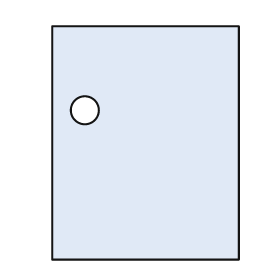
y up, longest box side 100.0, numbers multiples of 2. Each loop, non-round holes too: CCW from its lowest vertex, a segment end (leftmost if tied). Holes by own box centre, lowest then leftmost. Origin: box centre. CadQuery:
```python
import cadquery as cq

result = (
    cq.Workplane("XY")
    .moveTo(-40.0, -50.0)
    .lineTo(40.0, -50.0)
    .lineTo(40.0, 50.0)
    .lineTo(-40.0, 50.0)
    .close()
    .moveTo(-26.0, 14.0)
    .circle(6.0)
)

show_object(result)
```